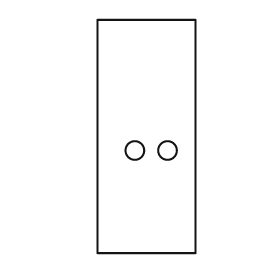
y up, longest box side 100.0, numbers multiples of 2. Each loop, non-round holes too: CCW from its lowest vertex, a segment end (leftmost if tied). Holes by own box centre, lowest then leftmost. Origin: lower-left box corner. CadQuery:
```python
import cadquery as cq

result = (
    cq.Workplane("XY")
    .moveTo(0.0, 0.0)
    .lineTo(42.0, 0.0)
    .lineTo(42.0, 100.0)
    .lineTo(0.0, 100.0)
    .close()
    .moveTo(16.0, 44.0)
    .circle(4.0)
    .moveTo(30.0, 44.0)
    .circle(4.0)
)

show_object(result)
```